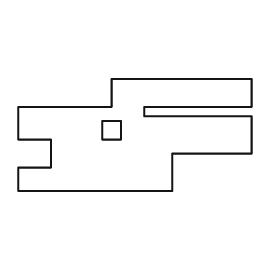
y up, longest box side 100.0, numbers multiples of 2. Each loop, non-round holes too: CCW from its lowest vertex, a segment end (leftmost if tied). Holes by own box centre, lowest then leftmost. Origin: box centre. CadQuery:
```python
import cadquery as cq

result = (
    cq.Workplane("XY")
    .moveTo(-50.0, -24.0)
    .lineTo(16.0, -24.0)
    .lineTo(16.0, -8.0)
    .lineTo(50.0, -8.0)
    .lineTo(50.0, 8.0)
    .lineTo(4.0, 8.0)
    .lineTo(4.0, 12.0)
    .lineTo(50.0, 12.0)
    .lineTo(50.0, 24.0)
    .lineTo(-10.0, 24.0)
    .lineTo(-10.0, 12.0)
    .lineTo(-50.0, 12.0)
    .lineTo(-50.0, -2.0)
    .lineTo(-36.0, -2.0)
    .lineTo(-36.0, -14.0)
    .lineTo(-50.0, -14.0)
    .close()
    .moveTo(-14.0, -2.0)
    .lineTo(-6.0, -2.0)
    .lineTo(-6.0, 6.0)
    .lineTo(-14.0, 6.0)
    .close()
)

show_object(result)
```